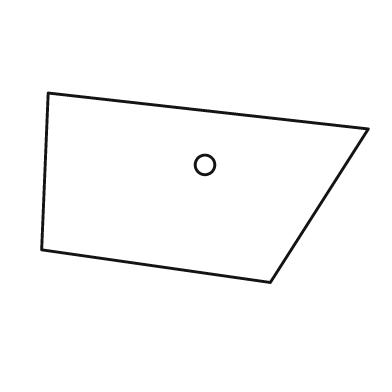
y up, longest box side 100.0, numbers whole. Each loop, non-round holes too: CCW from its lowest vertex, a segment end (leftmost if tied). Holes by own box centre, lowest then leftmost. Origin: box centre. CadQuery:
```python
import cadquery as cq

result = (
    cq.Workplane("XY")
    .moveTo(20.0, -29.0)
    .lineTo(50.0, 18.0)
    .lineTo(-48.0, 29.0)
    .lineTo(-50.0, -19.0)
    .close()
    .moveTo(0.0, 7.0)
    .circle(3.0)
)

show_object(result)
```